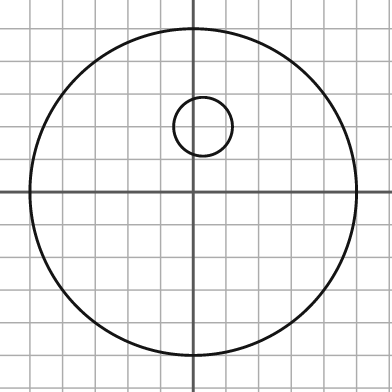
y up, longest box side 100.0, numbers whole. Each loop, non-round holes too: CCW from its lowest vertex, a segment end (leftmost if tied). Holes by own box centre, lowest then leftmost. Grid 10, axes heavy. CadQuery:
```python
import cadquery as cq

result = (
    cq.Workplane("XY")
    .moveTo(0.0, 0.0)
    .circle(50.0)
    .moveTo(3.0, 20.0)
    .circle(9.0)
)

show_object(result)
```